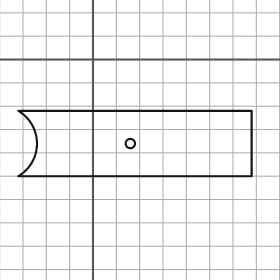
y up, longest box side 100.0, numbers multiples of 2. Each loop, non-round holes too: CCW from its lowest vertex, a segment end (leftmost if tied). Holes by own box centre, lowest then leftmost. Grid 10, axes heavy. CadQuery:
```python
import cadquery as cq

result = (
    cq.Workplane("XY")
    .moveTo(-32.0, -50.0)
    .lineTo(68.0, -50.0)
    .lineTo(68.0, -22.0)
    .lineTo(-32.0, -22.0)
    .threePointArc((-24.0, -36.0), (-32.0, -50.0))
    .close()
    .moveTo(16.0, -36.0)
    .circle(2.0)
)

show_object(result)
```